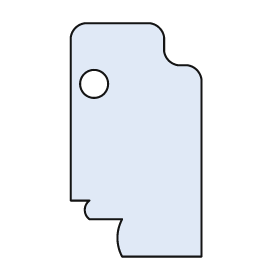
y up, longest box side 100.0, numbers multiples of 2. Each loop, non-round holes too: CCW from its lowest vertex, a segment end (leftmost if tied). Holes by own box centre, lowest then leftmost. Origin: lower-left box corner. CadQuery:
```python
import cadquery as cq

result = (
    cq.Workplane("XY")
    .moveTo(22.0, 0.0)
    .lineTo(56.0, 0.0)
    .lineTo(56.0, 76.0)
    .threePointArc((54.0, 80.0), (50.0, 82.0))
    .lineTo(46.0, 82.0)
    .threePointArc((42.0, 84.0), (40.0, 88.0))
    .lineTo(40.0, 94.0)
    .threePointArc((38.0, 98.0), (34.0, 100.0))
    .lineTo(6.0, 100.0)
    .threePointArc((2.0, 98.0), (0.0, 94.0))
    .lineTo(0.0, 24.0)
    .lineTo(8.0, 24.0)
    .threePointArc((6.0, 20.0), (8.0, 16.0))
    .lineTo(22.0, 16.0)
    .threePointArc((20.0, 8.0), (22.0, 0.0))
    .close()
    .moveTo(10.0, 74.0)
    .circle(6.0)
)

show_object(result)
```